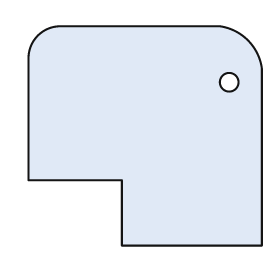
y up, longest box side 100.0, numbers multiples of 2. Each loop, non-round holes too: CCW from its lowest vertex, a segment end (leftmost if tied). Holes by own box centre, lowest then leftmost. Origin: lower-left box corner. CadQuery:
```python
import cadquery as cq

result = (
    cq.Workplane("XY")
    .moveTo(40.0, 0.0)
    .lineTo(100.0, 0.0)
    .lineTo(100.0, 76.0)
    .threePointArc((94.0, 88.0), (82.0, 94.0))
    .lineTo(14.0, 94.0)
    .threePointArc((4.0, 90.0), (0.0, 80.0))
    .lineTo(0.0, 28.0)
    .lineTo(40.0, 28.0)
    .close()
    .moveTo(86.0, 70.0)
    .circle(4.0)
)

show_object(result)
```